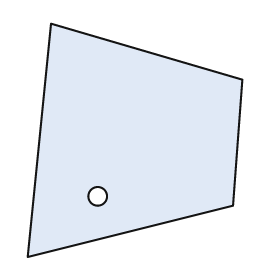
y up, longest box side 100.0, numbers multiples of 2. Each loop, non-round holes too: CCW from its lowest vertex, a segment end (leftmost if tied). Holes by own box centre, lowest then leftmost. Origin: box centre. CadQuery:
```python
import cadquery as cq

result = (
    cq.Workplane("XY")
    .moveTo(-46.0, -50.0)
    .lineTo(42.0, -28.0)
    .lineTo(46.0, 26.0)
    .lineTo(-36.0, 50.0)
    .close()
    .moveTo(-16.0, -24.0)
    .circle(4.0)
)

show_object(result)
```